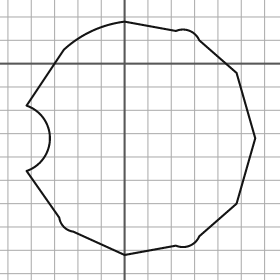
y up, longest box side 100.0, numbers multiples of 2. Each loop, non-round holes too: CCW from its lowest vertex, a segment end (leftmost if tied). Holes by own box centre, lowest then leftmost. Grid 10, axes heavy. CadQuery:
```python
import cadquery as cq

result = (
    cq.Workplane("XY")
    .moveTo(0.0, -82.0)
    .lineTo(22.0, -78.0)
    .threePointArc((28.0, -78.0), (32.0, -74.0))
    .lineTo(48.0, -60.0)
    .lineTo(56.0, -32.0)
    .lineTo(48.0, -4.0)
    .lineTo(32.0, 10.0)
    .threePointArc((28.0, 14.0), (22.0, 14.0))
    .lineTo(0.0, 18.0)
    .threePointArc((-14.0, 14.0), (-26.0, 6.0))
    .lineTo(-42.0, -18.0)
    .threePointArc((-32.0, -32.0), (-42.0, -46.0))
    .lineTo(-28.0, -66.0)
    .threePointArc((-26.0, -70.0), (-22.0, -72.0))
    .close()
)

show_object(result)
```